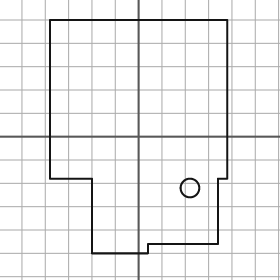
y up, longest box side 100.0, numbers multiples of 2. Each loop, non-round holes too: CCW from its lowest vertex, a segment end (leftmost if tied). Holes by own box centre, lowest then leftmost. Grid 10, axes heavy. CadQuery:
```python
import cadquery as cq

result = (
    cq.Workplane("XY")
    .moveTo(-20.0, -50.0)
    .lineTo(4.0, -50.0)
    .lineTo(4.0, -46.0)
    .lineTo(34.0, -46.0)
    .lineTo(34.0, -18.0)
    .lineTo(38.0, -18.0)
    .lineTo(38.0, 50.0)
    .lineTo(-38.0, 50.0)
    .lineTo(-38.0, -18.0)
    .lineTo(-20.0, -18.0)
    .close()
    .moveTo(22.0, -22.0)
    .circle(4.0)
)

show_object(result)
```